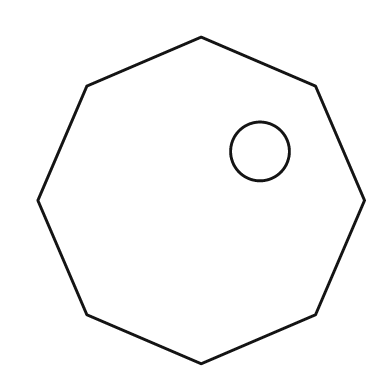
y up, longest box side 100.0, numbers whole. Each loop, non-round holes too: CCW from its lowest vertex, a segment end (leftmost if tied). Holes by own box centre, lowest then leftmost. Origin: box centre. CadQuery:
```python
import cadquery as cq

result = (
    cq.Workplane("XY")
    .moveTo(0.0, -50.0)
    .lineTo(35.0, -35.0)
    .lineTo(50.0, 0.0)
    .lineTo(35.0, 35.0)
    .lineTo(0.0, 50.0)
    .lineTo(-35.0, 35.0)
    .lineTo(-50.0, 0.0)
    .lineTo(-35.0, -35.0)
    .close()
    .moveTo(18.0, 15.0)
    .circle(9.0)
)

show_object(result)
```